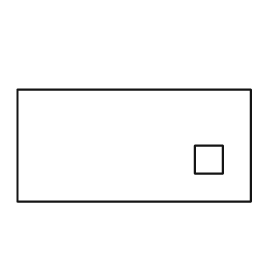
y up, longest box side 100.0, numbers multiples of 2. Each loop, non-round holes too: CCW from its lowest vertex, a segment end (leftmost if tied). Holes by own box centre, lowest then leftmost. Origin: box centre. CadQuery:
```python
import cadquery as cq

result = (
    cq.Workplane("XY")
    .moveTo(-50.0, -24.0)
    .lineTo(50.0, -24.0)
    .lineTo(50.0, 24.0)
    .lineTo(-50.0, 24.0)
    .close()
    .moveTo(26.0, -12.0)
    .lineTo(38.0, -12.0)
    .lineTo(38.0, 0.0)
    .lineTo(26.0, 0.0)
    .close()
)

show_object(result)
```